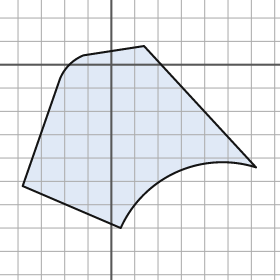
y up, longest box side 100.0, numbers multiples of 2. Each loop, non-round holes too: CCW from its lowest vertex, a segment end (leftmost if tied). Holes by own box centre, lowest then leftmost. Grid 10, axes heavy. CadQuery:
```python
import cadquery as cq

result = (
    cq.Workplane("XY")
    .moveTo(4.0, -70.0)
    .threePointArc((28.0, -46.0), (62.0, -44.0))
    .lineTo(14.0, 8.0)
    .lineTo(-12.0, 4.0)
    .threePointArc((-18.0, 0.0), (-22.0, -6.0))
    .lineTo(-38.0, -52.0)
    .close()
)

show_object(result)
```